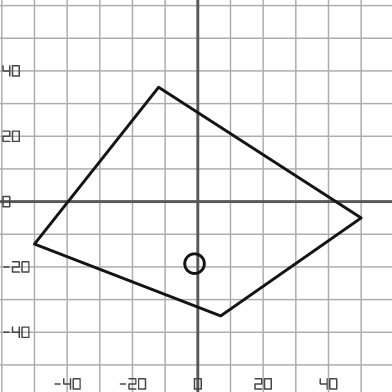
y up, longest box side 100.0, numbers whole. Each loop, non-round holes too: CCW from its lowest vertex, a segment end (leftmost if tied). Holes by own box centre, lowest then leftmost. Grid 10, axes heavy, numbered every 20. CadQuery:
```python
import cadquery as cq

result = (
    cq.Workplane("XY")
    .moveTo(7.0, -35.0)
    .lineTo(50.0, -5.0)
    .lineTo(-12.0, 35.0)
    .lineTo(-50.0, -13.0)
    .close()
    .moveTo(-1.0, -19.0)
    .circle(3.0)
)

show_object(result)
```